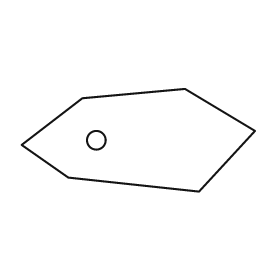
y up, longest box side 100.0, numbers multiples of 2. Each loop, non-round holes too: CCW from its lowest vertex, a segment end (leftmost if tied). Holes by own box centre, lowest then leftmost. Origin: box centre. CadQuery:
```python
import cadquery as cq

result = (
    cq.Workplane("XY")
    .moveTo(26.0, -22.0)
    .lineTo(50.0, 4.0)
    .lineTo(20.0, 22.0)
    .lineTo(-24.0, 18.0)
    .lineTo(-50.0, -2.0)
    .lineTo(-30.0, -16.0)
    .close()
    .moveTo(-18.0, 0.0)
    .circle(4.0)
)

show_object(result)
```